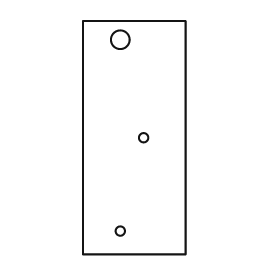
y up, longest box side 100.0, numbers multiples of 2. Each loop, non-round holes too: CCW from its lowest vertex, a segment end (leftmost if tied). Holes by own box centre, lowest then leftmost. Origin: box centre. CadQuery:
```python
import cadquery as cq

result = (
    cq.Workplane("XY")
    .moveTo(-22.0, -50.0)
    .lineTo(22.0, -50.0)
    .lineTo(22.0, 50.0)
    .lineTo(-22.0, 50.0)
    .close()
    .moveTo(-6.0, -40.0)
    .circle(2.0)
    .moveTo(4.0, 0.0)
    .circle(2.0)
    .moveTo(-6.0, 42.0)
    .circle(4.0)
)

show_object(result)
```